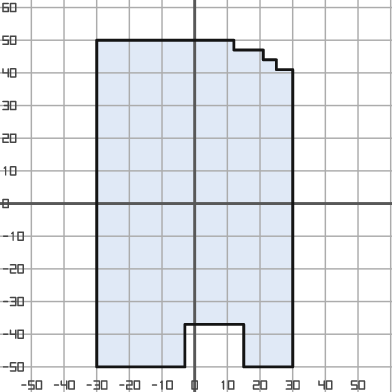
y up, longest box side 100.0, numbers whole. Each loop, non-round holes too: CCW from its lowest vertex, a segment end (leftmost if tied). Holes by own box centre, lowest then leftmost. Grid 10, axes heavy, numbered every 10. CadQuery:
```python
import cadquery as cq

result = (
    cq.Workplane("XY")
    .moveTo(-30.0, -50.0)
    .lineTo(-3.0, -50.0)
    .lineTo(-3.0, -37.0)
    .lineTo(15.0, -37.0)
    .lineTo(15.0, -50.0)
    .lineTo(30.0, -50.0)
    .lineTo(30.0, 41.0)
    .lineTo(25.0, 41.0)
    .lineTo(25.0, 44.0)
    .lineTo(21.0, 44.0)
    .lineTo(21.0, 47.0)
    .lineTo(12.0, 47.0)
    .lineTo(12.0, 50.0)
    .lineTo(-30.0, 50.0)
    .close()
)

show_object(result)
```